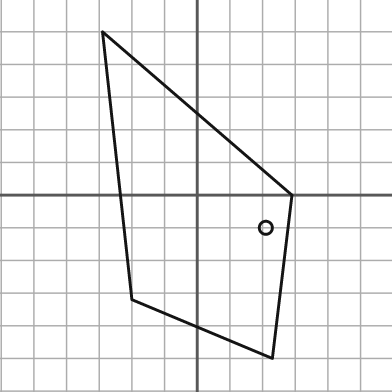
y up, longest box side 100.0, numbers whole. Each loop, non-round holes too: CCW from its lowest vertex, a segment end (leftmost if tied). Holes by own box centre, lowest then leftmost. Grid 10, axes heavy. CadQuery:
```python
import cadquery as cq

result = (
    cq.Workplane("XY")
    .moveTo(23.0, -50.0)
    .lineTo(29.0, 0.0)
    .lineTo(-29.0, 50.0)
    .lineTo(-20.0, -32.0)
    .close()
    .moveTo(21.0, -10.0)
    .circle(2.0)
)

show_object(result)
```